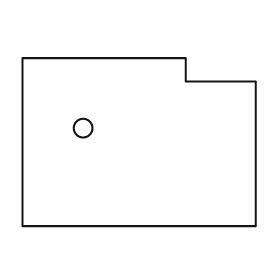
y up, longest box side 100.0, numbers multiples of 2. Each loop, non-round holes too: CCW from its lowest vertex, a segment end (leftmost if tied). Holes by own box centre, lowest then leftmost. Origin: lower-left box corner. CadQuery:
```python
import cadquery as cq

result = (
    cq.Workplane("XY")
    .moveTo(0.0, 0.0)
    .lineTo(100.0, 0.0)
    .lineTo(100.0, 62.0)
    .lineTo(70.0, 62.0)
    .lineTo(70.0, 72.0)
    .lineTo(0.0, 72.0)
    .close()
    .moveTo(26.0, 42.0)
    .circle(4.0)
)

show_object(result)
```